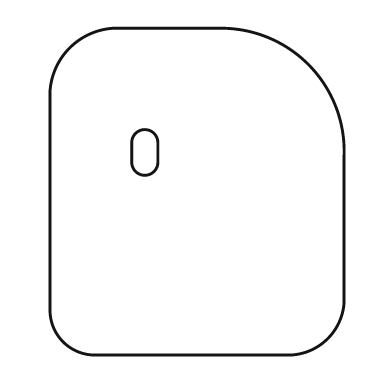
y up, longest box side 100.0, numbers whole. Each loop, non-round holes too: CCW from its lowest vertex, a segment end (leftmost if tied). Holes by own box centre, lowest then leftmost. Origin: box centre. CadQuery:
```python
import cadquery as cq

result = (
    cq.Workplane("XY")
    .moveTo(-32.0, -50.0)
    .lineTo(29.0, -50.0)
    .threePointArc((40.0, -45.0), (45.0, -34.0))
    .lineTo(45.0, 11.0)
    .threePointArc((34.0, 39.0), (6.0, 50.0))
    .lineTo(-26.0, 50.0)
    .threePointArc((-39.0, 44.0), (-45.0, 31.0))
    .lineTo(-45.0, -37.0)
    .threePointArc((-41.0, -46.0), (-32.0, -50.0))
    .close()
    .moveTo(-20.0, 9.0)
    .threePointArc((-16.0, 5.0), (-12.0, 9.0))
    .lineTo(-12.0, 15.0)
    .threePointArc((-16.0, 19.0), (-20.0, 15.0))
    .close()
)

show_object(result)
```